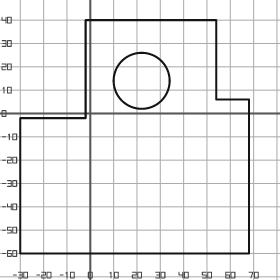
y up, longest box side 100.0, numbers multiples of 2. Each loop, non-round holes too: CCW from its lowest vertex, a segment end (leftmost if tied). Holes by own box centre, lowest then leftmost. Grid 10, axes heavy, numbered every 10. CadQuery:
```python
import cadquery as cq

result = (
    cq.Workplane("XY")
    .moveTo(-30.0, -60.0)
    .lineTo(68.0, -60.0)
    .lineTo(68.0, 6.0)
    .lineTo(54.0, 6.0)
    .lineTo(54.0, 40.0)
    .lineTo(-2.0, 40.0)
    .lineTo(-2.0, -2.0)
    .lineTo(-30.0, -2.0)
    .close()
    .moveTo(22.0, 14.0)
    .circle(12.0)
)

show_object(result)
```